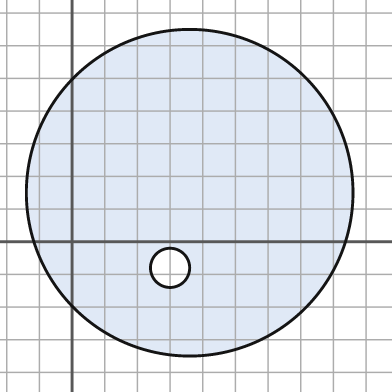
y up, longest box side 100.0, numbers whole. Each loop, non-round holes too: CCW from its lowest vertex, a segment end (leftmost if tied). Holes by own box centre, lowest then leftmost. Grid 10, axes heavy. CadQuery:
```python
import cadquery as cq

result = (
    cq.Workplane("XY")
    .moveTo(36.0, 15.0)
    .circle(50.0)
    .moveTo(30.0, -8.0)
    .circle(6.0)
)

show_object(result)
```